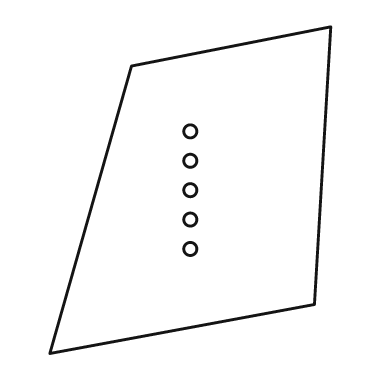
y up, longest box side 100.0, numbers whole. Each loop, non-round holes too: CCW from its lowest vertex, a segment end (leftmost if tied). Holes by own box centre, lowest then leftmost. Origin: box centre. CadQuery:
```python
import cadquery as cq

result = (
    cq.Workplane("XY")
    .moveTo(-43.0, -50.0)
    .lineTo(38.0, -35.0)
    .lineTo(43.0, 50.0)
    .lineTo(-18.0, 38.0)
    .close()
    .moveTo(0.0, -18.0)
    .circle(2.0)
    .moveTo(0.0, -9.0)
    .circle(2.0)
    .moveTo(0.0, 0.0)
    .circle(2.0)
    .moveTo(0.0, 9.0)
    .circle(2.0)
    .moveTo(0.0, 18.0)
    .circle(2.0)
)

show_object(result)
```